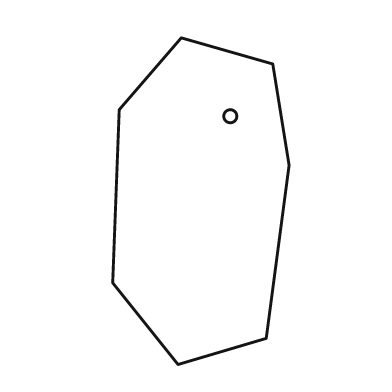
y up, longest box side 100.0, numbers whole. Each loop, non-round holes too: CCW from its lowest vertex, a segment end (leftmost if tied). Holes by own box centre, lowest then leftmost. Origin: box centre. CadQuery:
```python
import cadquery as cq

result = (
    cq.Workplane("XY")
    .moveTo(-7.0, -50.0)
    .lineTo(20.0, -42.0)
    .lineTo(27.0, 11.0)
    .lineTo(22.0, 42.0)
    .lineTo(-6.0, 50.0)
    .lineTo(-25.0, 28.0)
    .lineTo(-27.0, -25.0)
    .close()
    .moveTo(9.0, 26.0)
    .circle(2.0)
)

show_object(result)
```